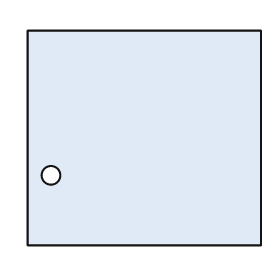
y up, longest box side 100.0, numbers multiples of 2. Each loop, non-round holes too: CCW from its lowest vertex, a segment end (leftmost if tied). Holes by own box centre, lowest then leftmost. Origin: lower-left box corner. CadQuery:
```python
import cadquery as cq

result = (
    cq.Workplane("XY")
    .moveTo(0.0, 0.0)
    .lineTo(100.0, 0.0)
    .lineTo(100.0, 92.0)
    .lineTo(0.0, 92.0)
    .close()
    .moveTo(10.0, 30.0)
    .circle(4.0)
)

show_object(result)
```